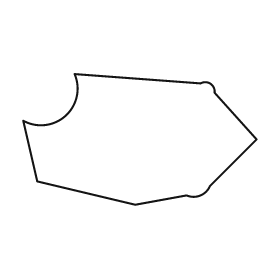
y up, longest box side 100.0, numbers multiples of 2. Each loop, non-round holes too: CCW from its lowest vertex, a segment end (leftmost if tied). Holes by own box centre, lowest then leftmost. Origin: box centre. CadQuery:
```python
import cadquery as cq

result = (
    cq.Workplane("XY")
    .moveTo(-2.0, -28.0)
    .lineTo(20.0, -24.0)
    .threePointArc((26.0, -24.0), (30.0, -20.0))
    .lineTo(50.0, 0.0)
    .lineTo(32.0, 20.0)
    .threePointArc((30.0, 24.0), (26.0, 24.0))
    .lineTo(-28.0, 28.0)
    .threePointArc((-32.0, 10.0), (-50.0, 8.0))
    .lineTo(-44.0, -18.0)
    .close()
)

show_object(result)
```